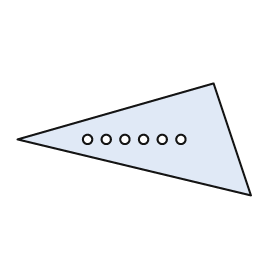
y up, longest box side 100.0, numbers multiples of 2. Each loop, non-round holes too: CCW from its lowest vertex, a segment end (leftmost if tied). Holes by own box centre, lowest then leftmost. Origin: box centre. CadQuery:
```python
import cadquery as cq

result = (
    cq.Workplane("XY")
    .moveTo(50.0, -24.0)
    .lineTo(34.0, 24.0)
    .lineTo(-50.0, 0.0)
    .close()
    .moveTo(-20.0, 0.0)
    .circle(2.0)
    .moveTo(-12.0, 0.0)
    .circle(2.0)
    .moveTo(-4.0, 0.0)
    .circle(2.0)
    .moveTo(4.0, 0.0)
    .circle(2.0)
    .moveTo(12.0, 0.0)
    .circle(2.0)
    .moveTo(20.0, 0.0)
    .circle(2.0)
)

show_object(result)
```